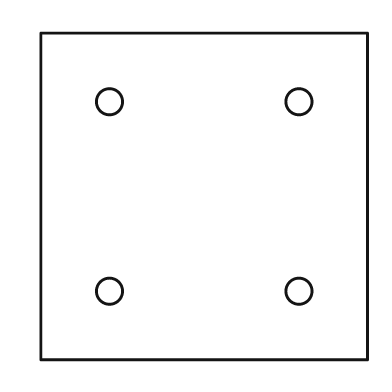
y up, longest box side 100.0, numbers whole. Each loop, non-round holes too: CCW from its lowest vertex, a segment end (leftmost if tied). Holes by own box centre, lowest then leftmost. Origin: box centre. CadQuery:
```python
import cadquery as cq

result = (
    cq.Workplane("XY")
    .moveTo(-50.0, -50.0)
    .lineTo(50.0, -50.0)
    .lineTo(50.0, 50.0)
    .lineTo(-50.0, 50.0)
    .close()
    .moveTo(-29.0, -29.0)
    .circle(4.0)
    .moveTo(29.0, -29.0)
    .circle(4.0)
    .moveTo(-29.0, 29.0)
    .circle(4.0)
    .moveTo(29.0, 29.0)
    .circle(4.0)
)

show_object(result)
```